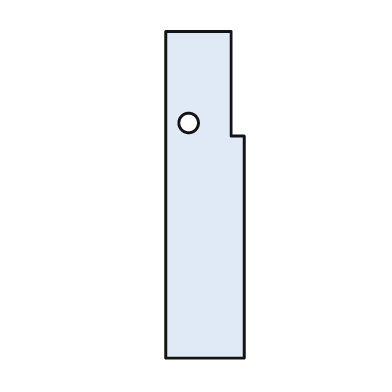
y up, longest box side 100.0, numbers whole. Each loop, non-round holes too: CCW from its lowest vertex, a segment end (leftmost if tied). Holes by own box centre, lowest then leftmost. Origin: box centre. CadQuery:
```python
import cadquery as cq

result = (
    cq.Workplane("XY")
    .moveTo(-12.0, -50.0)
    .lineTo(12.0, -50.0)
    .lineTo(12.0, 18.0)
    .lineTo(8.0, 18.0)
    .lineTo(8.0, 50.0)
    .lineTo(-12.0, 50.0)
    .close()
    .moveTo(-5.0, 22.0)
    .circle(3.0)
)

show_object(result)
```